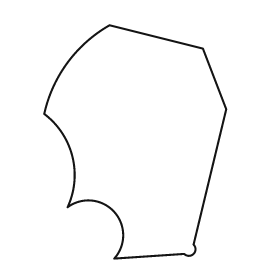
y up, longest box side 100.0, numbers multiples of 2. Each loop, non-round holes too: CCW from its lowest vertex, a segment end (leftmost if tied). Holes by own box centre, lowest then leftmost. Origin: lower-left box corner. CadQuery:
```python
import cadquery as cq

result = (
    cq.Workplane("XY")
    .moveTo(30.0, 0.0)
    .lineTo(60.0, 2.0)
    .threePointArc((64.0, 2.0), (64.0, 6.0))
    .lineTo(78.0, 64.0)
    .lineTo(68.0, 90.0)
    .lineTo(28.0, 100.0)
    .threePointArc((10.0, 84.0), (0.0, 62.0))
    .threePointArc((12.0, 44.0), (10.0, 22.0))
    .threePointArc((30.0, 20.0), (30.0, 0.0))
    .close()
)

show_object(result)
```